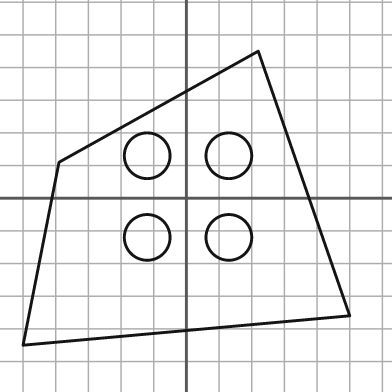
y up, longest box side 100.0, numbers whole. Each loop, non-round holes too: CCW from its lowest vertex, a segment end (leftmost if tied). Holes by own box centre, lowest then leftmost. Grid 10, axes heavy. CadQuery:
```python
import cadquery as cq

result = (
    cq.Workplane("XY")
    .moveTo(-50.0, -45.0)
    .lineTo(50.0, -36.0)
    .lineTo(22.0, 45.0)
    .lineTo(-39.0, 11.0)
    .close()
    .moveTo(-12.0, -12.0)
    .circle(7.0)
    .moveTo(13.0, -12.0)
    .circle(7.0)
    .moveTo(-12.0, 13.0)
    .circle(7.0)
    .moveTo(13.0, 13.0)
    .circle(7.0)
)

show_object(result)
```